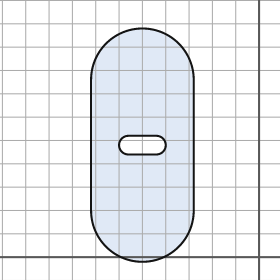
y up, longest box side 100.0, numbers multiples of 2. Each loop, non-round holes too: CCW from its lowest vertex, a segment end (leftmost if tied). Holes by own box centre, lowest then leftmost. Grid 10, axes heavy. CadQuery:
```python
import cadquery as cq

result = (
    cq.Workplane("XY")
    .moveTo(-72.0, 20.0)
    .threePointArc((-50.0, -2.0), (-28.0, 20.0))
    .lineTo(-28.0, 76.0)
    .threePointArc((-50.0, 98.0), (-72.0, 76.0))
    .close()
    .moveTo(-56.0, 44.0)
    .lineTo(-44.0, 44.0)
    .threePointArc((-40.0, 48.0), (-44.0, 52.0))
    .lineTo(-56.0, 52.0)
    .threePointArc((-60.0, 48.0), (-56.0, 44.0))
    .close()
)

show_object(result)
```